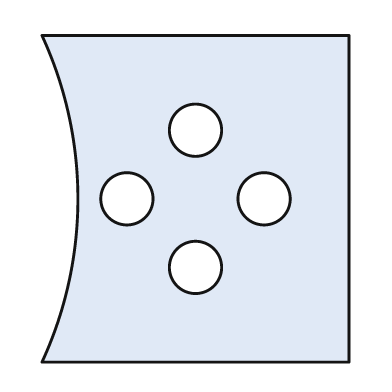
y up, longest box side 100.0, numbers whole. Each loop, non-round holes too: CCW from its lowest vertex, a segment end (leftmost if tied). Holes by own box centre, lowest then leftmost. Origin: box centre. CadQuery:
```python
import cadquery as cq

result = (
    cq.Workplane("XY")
    .moveTo(-47.0, -50.0)
    .lineTo(47.0, -50.0)
    .lineTo(47.0, 50.0)
    .lineTo(-47.0, 50.0)
    .threePointArc((-36.0, 0.0), (-47.0, -50.0))
    .close()
    .moveTo(0.0, -21.0)
    .circle(8.0)
    .moveTo(-21.0, 0.0)
    .circle(8.0)
    .moveTo(21.0, 0.0)
    .circle(8.0)
    .moveTo(0.0, 21.0)
    .circle(8.0)
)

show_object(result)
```